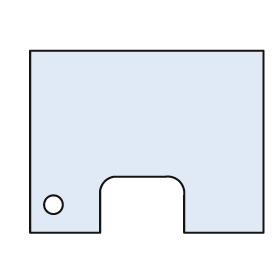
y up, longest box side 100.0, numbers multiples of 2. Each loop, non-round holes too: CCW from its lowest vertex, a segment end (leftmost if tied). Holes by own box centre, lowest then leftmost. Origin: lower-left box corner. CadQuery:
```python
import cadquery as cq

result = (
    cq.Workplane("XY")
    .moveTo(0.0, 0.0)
    .lineTo(30.0, 0.0)
    .lineTo(30.0, 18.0)
    .threePointArc((32.0, 22.0), (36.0, 24.0))
    .lineTo(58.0, 24.0)
    .threePointArc((64.0, 22.0), (66.0, 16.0))
    .lineTo(66.0, 0.0)
    .lineTo(100.0, 0.0)
    .lineTo(100.0, 78.0)
    .lineTo(0.0, 78.0)
    .close()
    .moveTo(10.0, 12.0)
    .circle(4.0)
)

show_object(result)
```